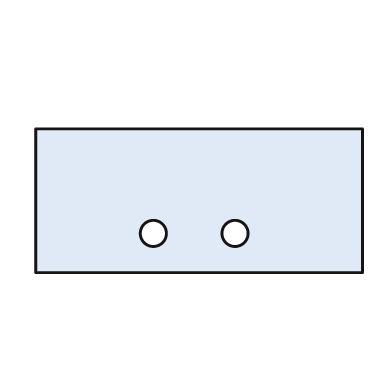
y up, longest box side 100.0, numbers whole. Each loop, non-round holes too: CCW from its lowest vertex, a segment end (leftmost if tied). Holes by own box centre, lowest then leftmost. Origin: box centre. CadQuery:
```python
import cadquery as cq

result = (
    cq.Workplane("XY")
    .moveTo(-50.0, -22.0)
    .lineTo(50.0, -22.0)
    .lineTo(50.0, 22.0)
    .lineTo(-50.0, 22.0)
    .close()
    .moveTo(-14.0, -10.0)
    .circle(4.0)
    .moveTo(11.0, -10.0)
    .circle(4.0)
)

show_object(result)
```